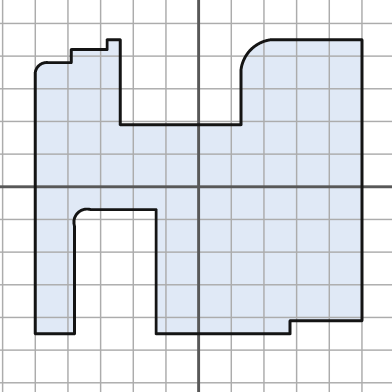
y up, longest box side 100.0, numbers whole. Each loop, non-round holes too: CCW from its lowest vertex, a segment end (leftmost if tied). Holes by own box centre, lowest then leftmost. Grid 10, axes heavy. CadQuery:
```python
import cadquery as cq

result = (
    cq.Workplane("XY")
    .moveTo(-50.0, -45.0)
    .lineTo(-38.0, -45.0)
    .lineTo(-38.0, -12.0)
    .threePointArc((-37.0, -8.0), (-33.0, -7.0))
    .lineTo(-13.0, -7.0)
    .lineTo(-13.0, -45.0)
    .lineTo(28.0, -45.0)
    .lineTo(28.0, -41.0)
    .lineTo(50.0, -41.0)
    .lineTo(50.0, 45.0)
    .lineTo(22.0, 45.0)
    .threePointArc((16.0, 42.0), (13.0, 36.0))
    .lineTo(13.0, 19.0)
    .lineTo(-24.0, 19.0)
    .lineTo(-24.0, 45.0)
    .lineTo(-28.0, 45.0)
    .lineTo(-28.0, 42.0)
    .lineTo(-39.0, 42.0)
    .lineTo(-39.0, 38.0)
    .lineTo(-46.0, 38.0)
    .threePointArc((-49.0, 37.0), (-50.0, 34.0))
    .close()
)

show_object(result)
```